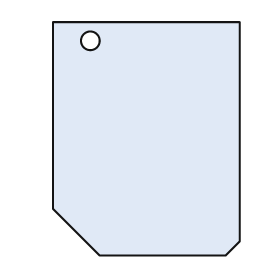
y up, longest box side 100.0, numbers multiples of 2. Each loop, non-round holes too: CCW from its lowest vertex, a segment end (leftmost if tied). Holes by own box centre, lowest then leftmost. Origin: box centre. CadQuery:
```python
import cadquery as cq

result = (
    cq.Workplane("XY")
    .moveTo(-20.0, -50.0)
    .lineTo(34.0, -50.0)
    .lineTo(40.0, -44.0)
    .lineTo(40.0, 50.0)
    .lineTo(-40.0, 50.0)
    .lineTo(-40.0, -30.0)
    .close()
    .moveTo(-24.0, 42.0)
    .circle(4.0)
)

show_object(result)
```